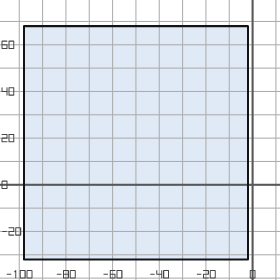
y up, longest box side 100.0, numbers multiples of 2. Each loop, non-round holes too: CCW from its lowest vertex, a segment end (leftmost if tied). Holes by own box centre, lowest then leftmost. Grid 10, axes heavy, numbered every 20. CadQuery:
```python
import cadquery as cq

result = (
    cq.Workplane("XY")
    .moveTo(-98.0, -32.0)
    .lineTo(-2.0, -32.0)
    .lineTo(-2.0, 68.0)
    .lineTo(-98.0, 68.0)
    .close()
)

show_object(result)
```